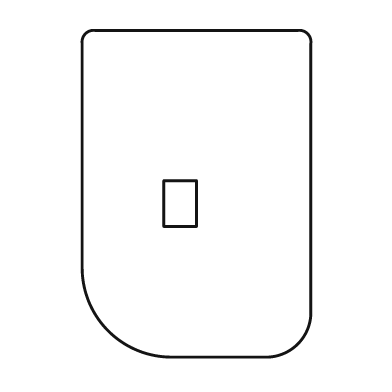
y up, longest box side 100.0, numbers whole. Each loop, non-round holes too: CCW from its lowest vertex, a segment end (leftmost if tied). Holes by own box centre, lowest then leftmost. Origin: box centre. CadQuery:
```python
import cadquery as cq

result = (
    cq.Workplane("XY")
    .moveTo(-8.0, -50.0)
    .lineTo(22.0, -50.0)
    .threePointArc((31.0, -46.0), (35.0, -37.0))
    .lineTo(35.0, 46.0)
    .threePointArc((34.0, 49.0), (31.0, 50.0))
    .lineTo(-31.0, 50.0)
    .threePointArc((-34.0, 49.0), (-35.0, 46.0))
    .lineTo(-35.0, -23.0)
    .threePointArc((-27.0, -42.0), (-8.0, -50.0))
    .close()
    .moveTo(-10.0, -10.0)
    .lineTo(0.0, -10.0)
    .lineTo(0.0, 4.0)
    .lineTo(-10.0, 4.0)
    .close()
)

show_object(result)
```